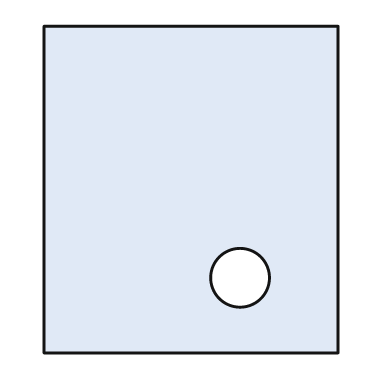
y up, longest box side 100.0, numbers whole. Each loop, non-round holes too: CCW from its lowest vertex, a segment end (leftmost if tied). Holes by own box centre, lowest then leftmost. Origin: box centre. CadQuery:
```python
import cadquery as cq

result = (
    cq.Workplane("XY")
    .moveTo(-45.0, -50.0)
    .lineTo(45.0, -50.0)
    .lineTo(45.0, 50.0)
    .lineTo(-45.0, 50.0)
    .close()
    .moveTo(15.0, -27.0)
    .circle(9.0)
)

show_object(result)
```